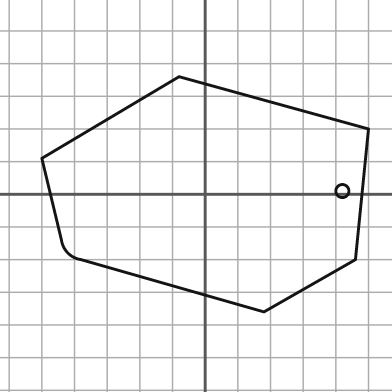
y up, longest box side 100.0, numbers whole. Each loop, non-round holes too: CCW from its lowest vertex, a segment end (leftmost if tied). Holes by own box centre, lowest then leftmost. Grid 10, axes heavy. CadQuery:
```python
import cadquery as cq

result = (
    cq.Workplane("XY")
    .moveTo(18.0, -36.0)
    .lineTo(46.0, -20.0)
    .lineTo(50.0, 20.0)
    .lineTo(-8.0, 36.0)
    .lineTo(-50.0, 11.0)
    .lineTo(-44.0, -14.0)
    .threePointArc((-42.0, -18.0), (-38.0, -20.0))
    .close()
    .moveTo(42.0, 1.0)
    .circle(2.0)
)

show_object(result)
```